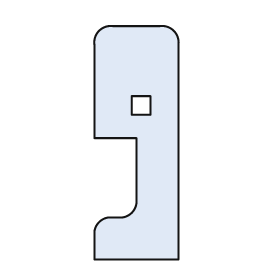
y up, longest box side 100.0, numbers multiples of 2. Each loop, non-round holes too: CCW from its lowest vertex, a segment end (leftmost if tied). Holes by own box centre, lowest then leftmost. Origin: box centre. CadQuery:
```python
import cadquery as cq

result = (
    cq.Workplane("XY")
    .moveTo(-18.0, -50.0)
    .lineTo(18.0, -50.0)
    .lineTo(18.0, 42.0)
    .threePointArc((16.0, 48.0), (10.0, 50.0))
    .lineTo(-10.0, 50.0)
    .threePointArc((-16.0, 48.0), (-18.0, 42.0))
    .lineTo(-18.0, 2.0)
    .lineTo(0.0, 2.0)
    .lineTo(0.0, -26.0)
    .threePointArc((-2.0, -30.0), (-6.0, -32.0))
    .lineTo(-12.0, -32.0)
    .threePointArc((-16.0, -34.0), (-18.0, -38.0))
    .close()
    .moveTo(-2.0, 12.0)
    .lineTo(6.0, 12.0)
    .lineTo(6.0, 20.0)
    .lineTo(-2.0, 20.0)
    .close()
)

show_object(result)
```